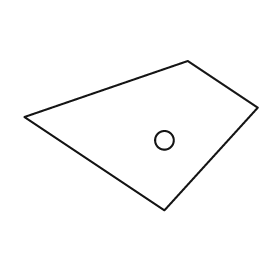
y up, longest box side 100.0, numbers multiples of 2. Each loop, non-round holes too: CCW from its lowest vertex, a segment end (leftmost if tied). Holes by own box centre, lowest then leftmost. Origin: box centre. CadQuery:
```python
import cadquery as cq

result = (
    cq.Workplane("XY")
    .moveTo(10.0, -32.0)
    .lineTo(50.0, 12.0)
    .lineTo(20.0, 32.0)
    .lineTo(-50.0, 8.0)
    .close()
    .moveTo(10.0, -2.0)
    .circle(4.0)
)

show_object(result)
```